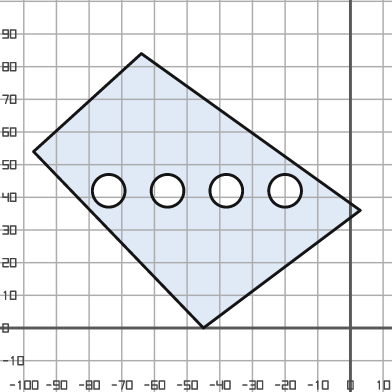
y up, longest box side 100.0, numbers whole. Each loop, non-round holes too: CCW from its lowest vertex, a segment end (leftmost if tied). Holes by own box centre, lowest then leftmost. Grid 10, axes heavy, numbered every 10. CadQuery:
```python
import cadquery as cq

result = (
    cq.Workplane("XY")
    .moveTo(-45.0, 0.0)
    .lineTo(3.0, 36.0)
    .lineTo(-64.0, 84.0)
    .lineTo(-97.0, 54.0)
    .close()
    .moveTo(-74.0, 42.0)
    .circle(5.0)
    .moveTo(-56.0, 42.0)
    .circle(5.0)
    .moveTo(-38.0, 42.0)
    .circle(5.0)
    .moveTo(-20.0, 42.0)
    .circle(5.0)
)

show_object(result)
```